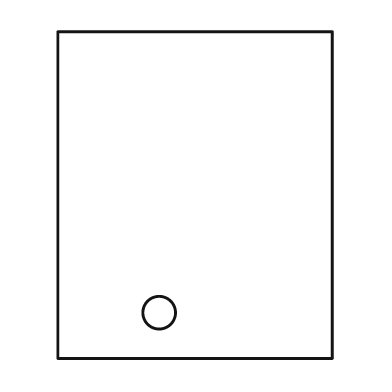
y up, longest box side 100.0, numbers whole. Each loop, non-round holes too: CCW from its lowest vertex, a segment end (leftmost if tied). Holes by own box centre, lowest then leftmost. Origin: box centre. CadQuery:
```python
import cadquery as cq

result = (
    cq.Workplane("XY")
    .moveTo(-42.0, -50.0)
    .lineTo(42.0, -50.0)
    .lineTo(42.0, 50.0)
    .lineTo(-42.0, 50.0)
    .close()
    .moveTo(-11.0, -36.0)
    .circle(5.0)
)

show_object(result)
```